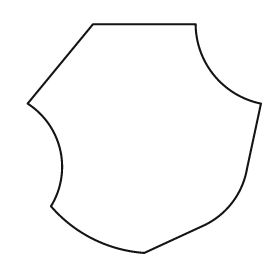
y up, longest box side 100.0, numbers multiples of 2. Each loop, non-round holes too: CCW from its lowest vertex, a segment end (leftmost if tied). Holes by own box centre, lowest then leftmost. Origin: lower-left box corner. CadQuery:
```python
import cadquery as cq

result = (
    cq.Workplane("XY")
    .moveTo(50.0, 0.0)
    .lineTo(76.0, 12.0)
    .threePointArc((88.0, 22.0), (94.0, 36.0))
    .lineTo(100.0, 64.0)
    .threePointArc((80.0, 76.0), (72.0, 98.0))
    .lineTo(28.0, 98.0)
    .lineTo(0.0, 64.0)
    .threePointArc((14.0, 44.0), (10.0, 20.0))
    .threePointArc((28.0, 6.0), (50.0, 0.0))
    .close()
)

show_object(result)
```